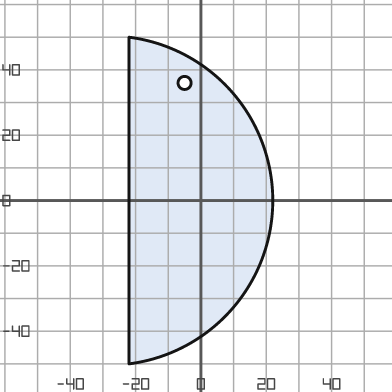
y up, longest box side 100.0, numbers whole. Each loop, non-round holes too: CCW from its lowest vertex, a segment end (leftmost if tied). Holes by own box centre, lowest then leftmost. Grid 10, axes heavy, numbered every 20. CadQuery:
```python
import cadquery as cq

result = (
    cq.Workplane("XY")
    .moveTo(-22.0, -50.0)
    .threePointArc((22.0, 0.0), (-22.0, 50.0))
    .close()
    .moveTo(-5.0, 36.0)
    .circle(2.0)
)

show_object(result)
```